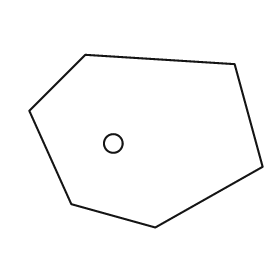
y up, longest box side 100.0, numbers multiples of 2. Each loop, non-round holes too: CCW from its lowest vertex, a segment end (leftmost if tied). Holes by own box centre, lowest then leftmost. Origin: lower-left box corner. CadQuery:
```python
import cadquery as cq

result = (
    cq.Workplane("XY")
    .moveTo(54.0, 0.0)
    .lineTo(100.0, 26.0)
    .lineTo(88.0, 70.0)
    .lineTo(24.0, 74.0)
    .lineTo(0.0, 50.0)
    .lineTo(18.0, 10.0)
    .close()
    .moveTo(36.0, 36.0)
    .circle(4.0)
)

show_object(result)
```